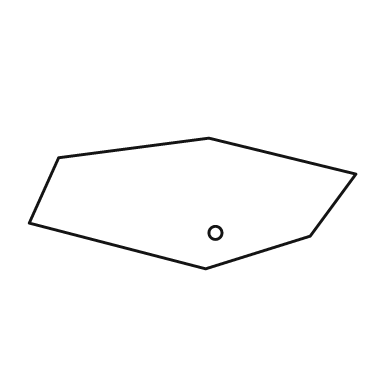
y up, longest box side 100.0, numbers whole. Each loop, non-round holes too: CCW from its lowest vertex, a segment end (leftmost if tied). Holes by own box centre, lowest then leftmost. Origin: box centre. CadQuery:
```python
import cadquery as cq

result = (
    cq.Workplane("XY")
    .moveTo(4.0, -20.0)
    .lineTo(36.0, -10.0)
    .lineTo(50.0, 9.0)
    .lineTo(5.0, 20.0)
    .lineTo(-41.0, 14.0)
    .lineTo(-50.0, -6.0)
    .close()
    .moveTo(7.0, -9.0)
    .circle(2.0)
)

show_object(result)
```